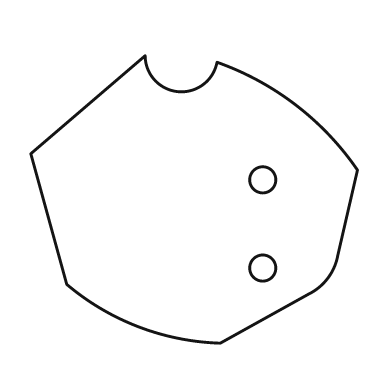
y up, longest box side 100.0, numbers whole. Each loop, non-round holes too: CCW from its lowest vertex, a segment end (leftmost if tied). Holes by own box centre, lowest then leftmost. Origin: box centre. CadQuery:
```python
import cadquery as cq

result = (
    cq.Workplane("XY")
    .moveTo(8.0, -44.0)
    .lineTo(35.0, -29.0)
    .threePointArc((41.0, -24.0), (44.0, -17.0))
    .lineTo(50.0, 9.0)
    .threePointArc((31.0, 29.0), (7.0, 42.0))
    .threePointArc((-5.0, 33.0), (-15.0, 44.0))
    .lineTo(-50.0, 14.0)
    .lineTo(-39.0, -26.0)
    .threePointArc((-17.0, -39.0), (8.0, -44.0))
    .close()
    .moveTo(21.0, -21.0)
    .circle(4.0)
    .moveTo(21.0, 6.0)
    .circle(4.0)
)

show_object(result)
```